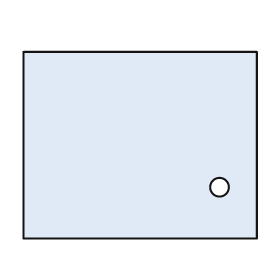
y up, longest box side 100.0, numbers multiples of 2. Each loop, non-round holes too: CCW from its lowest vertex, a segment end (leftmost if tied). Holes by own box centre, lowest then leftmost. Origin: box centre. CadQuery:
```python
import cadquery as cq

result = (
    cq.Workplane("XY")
    .moveTo(-50.0, -40.0)
    .lineTo(50.0, -40.0)
    .lineTo(50.0, 40.0)
    .lineTo(-50.0, 40.0)
    .close()
    .moveTo(34.0, -18.0)
    .circle(4.0)
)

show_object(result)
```